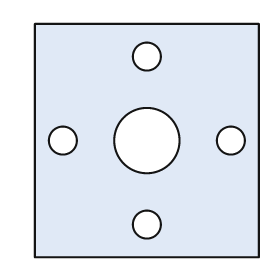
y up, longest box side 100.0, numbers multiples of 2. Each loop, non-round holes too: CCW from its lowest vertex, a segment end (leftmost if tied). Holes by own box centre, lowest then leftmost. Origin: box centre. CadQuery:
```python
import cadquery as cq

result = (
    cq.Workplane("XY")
    .moveTo(-48.0, -50.0)
    .lineTo(48.0, -50.0)
    .lineTo(48.0, 50.0)
    .lineTo(-48.0, 50.0)
    .close()
    .moveTo(0.0, -36.0)
    .circle(6.0)
    .moveTo(-36.0, 0.0)
    .circle(6.0)
    .moveTo(0.0, 0.0)
    .circle(14.0)
    .moveTo(36.0, 0.0)
    .circle(6.0)
    .moveTo(0.0, 36.0)
    .circle(6.0)
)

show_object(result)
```